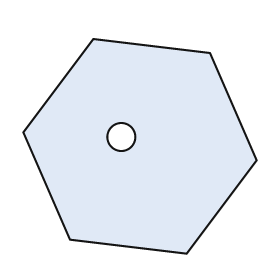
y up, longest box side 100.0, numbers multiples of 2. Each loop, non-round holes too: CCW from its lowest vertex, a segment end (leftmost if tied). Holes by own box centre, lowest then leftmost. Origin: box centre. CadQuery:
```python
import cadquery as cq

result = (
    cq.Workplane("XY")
    .moveTo(20.0, -46.0)
    .lineTo(50.0, -6.0)
    .lineTo(30.0, 40.0)
    .lineTo(-20.0, 46.0)
    .lineTo(-50.0, 6.0)
    .lineTo(-30.0, -40.0)
    .close()
    .moveTo(-8.0, 4.0)
    .circle(6.0)
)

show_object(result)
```